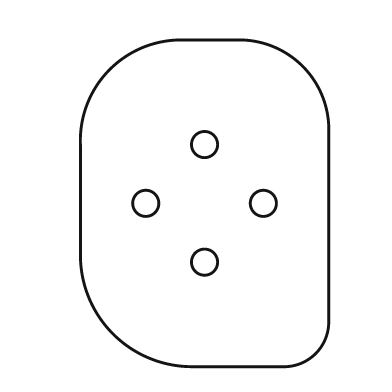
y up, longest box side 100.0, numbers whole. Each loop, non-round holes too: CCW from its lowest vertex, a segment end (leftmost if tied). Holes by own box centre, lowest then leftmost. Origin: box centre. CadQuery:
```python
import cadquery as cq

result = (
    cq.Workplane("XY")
    .moveTo(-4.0, -50.0)
    .lineTo(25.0, -50.0)
    .threePointArc((34.0, -46.0), (38.0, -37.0))
    .lineTo(38.0, 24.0)
    .threePointArc((30.0, 42.0), (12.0, 50.0))
    .lineTo(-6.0, 50.0)
    .threePointArc((-29.0, 41.0), (-38.0, 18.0))
    .lineTo(-38.0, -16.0)
    .threePointArc((-28.0, -40.0), (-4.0, -50.0))
    .close()
    .moveTo(0.0, -18.0)
    .circle(4.0)
    .moveTo(-18.0, 0.0)
    .circle(4.0)
    .moveTo(18.0, 0.0)
    .circle(4.0)
    .moveTo(0.0, 18.0)
    .circle(4.0)
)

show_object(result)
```